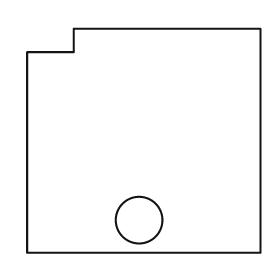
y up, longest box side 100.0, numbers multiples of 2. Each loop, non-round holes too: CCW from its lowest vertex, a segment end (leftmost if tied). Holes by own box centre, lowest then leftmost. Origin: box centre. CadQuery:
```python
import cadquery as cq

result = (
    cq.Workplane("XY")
    .moveTo(-50.0, -48.0)
    .lineTo(50.0, -48.0)
    .lineTo(50.0, 48.0)
    .lineTo(-30.0, 48.0)
    .lineTo(-30.0, 38.0)
    .lineTo(-50.0, 38.0)
    .close()
    .moveTo(-2.0, -34.0)
    .circle(10.0)
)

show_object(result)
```